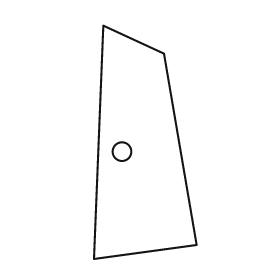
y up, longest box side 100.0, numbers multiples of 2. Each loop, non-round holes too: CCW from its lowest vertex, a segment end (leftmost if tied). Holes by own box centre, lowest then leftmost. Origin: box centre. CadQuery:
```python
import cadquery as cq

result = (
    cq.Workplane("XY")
    .moveTo(-22.0, -50.0)
    .lineTo(22.0, -44.0)
    .lineTo(8.0, 38.0)
    .lineTo(-18.0, 50.0)
    .close()
    .moveTo(-10.0, -4.0)
    .circle(4.0)
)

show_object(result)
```